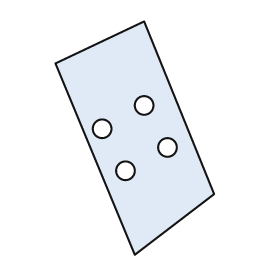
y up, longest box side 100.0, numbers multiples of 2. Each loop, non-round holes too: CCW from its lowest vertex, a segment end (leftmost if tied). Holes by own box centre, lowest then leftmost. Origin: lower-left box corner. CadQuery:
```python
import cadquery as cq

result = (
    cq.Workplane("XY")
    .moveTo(34.0, 0.0)
    .lineTo(68.0, 26.0)
    .lineTo(38.0, 100.0)
    .lineTo(0.0, 82.0)
    .close()
    .moveTo(30.0, 36.0)
    .circle(4.0)
    .moveTo(48.0, 46.0)
    .circle(4.0)
    .moveTo(20.0, 54.0)
    .circle(4.0)
    .moveTo(38.0, 64.0)
    .circle(4.0)
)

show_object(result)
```